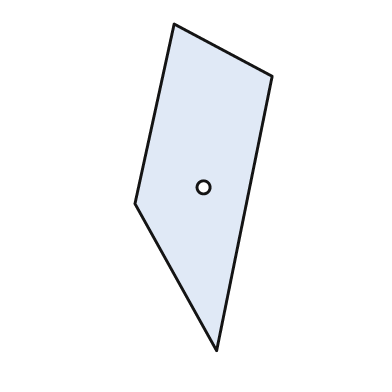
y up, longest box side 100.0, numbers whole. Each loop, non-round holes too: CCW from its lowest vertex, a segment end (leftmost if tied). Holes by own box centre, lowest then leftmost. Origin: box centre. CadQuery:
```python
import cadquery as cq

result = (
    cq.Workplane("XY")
    .moveTo(4.0, -50.0)
    .lineTo(21.0, 34.0)
    .lineTo(-9.0, 50.0)
    .lineTo(-21.0, -5.0)
    .close()
    .moveTo(0.0, 0.0)
    .circle(2.0)
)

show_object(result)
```